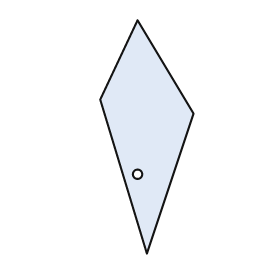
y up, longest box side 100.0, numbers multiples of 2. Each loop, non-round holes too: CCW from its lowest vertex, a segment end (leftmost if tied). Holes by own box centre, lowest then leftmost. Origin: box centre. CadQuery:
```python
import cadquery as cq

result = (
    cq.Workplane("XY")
    .moveTo(0.0, -50.0)
    .lineTo(20.0, 10.0)
    .lineTo(-4.0, 50.0)
    .lineTo(-20.0, 16.0)
    .close()
    .moveTo(-4.0, -16.0)
    .circle(2.0)
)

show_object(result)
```